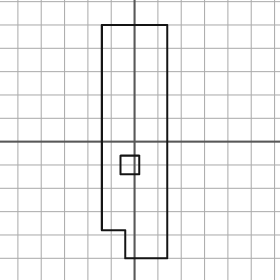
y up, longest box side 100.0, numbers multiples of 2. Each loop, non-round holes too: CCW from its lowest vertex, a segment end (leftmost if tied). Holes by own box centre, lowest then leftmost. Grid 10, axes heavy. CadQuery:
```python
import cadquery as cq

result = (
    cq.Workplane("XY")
    .moveTo(-4.0, -50.0)
    .lineTo(14.0, -50.0)
    .lineTo(14.0, 50.0)
    .lineTo(-14.0, 50.0)
    .lineTo(-14.0, -38.0)
    .lineTo(-4.0, -38.0)
    .close()
    .moveTo(-6.0, -14.0)
    .lineTo(2.0, -14.0)
    .lineTo(2.0, -6.0)
    .lineTo(-6.0, -6.0)
    .close()
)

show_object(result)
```